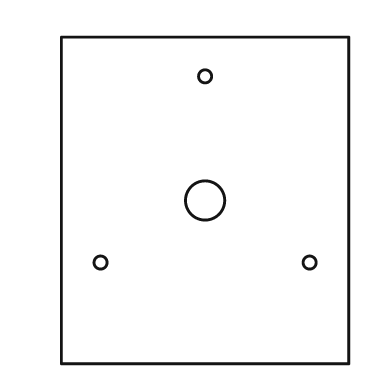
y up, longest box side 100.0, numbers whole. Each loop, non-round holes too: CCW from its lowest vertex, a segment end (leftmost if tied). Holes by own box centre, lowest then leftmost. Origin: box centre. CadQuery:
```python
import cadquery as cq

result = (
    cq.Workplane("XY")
    .moveTo(-44.0, -50.0)
    .lineTo(44.0, -50.0)
    .lineTo(44.0, 50.0)
    .lineTo(-44.0, 50.0)
    .close()
    .moveTo(-32.0, -19.0)
    .circle(2.0)
    .moveTo(32.0, -19.0)
    .circle(2.0)
    .moveTo(0.0, 0.0)
    .circle(6.0)
    .moveTo(0.0, 38.0)
    .circle(2.0)
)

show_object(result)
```